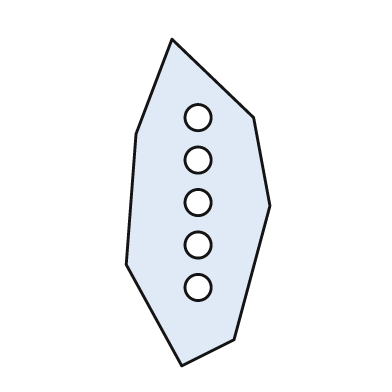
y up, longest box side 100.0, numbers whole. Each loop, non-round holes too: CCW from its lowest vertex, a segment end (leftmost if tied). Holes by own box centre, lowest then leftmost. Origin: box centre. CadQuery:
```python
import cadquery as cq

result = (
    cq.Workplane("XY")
    .moveTo(-5.0, -50.0)
    .lineTo(11.0, -42.0)
    .lineTo(22.0, -1.0)
    .lineTo(17.0, 26.0)
    .lineTo(-8.0, 50.0)
    .lineTo(-19.0, 21.0)
    .lineTo(-22.0, -19.0)
    .close()
    .moveTo(0.0, -26.0)
    .circle(4.0)
    .moveTo(0.0, -13.0)
    .circle(4.0)
    .moveTo(0.0, 0.0)
    .circle(4.0)
    .moveTo(0.0, 13.0)
    .circle(4.0)
    .moveTo(0.0, 26.0)
    .circle(4.0)
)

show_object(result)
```